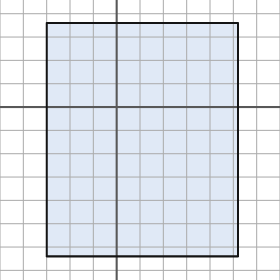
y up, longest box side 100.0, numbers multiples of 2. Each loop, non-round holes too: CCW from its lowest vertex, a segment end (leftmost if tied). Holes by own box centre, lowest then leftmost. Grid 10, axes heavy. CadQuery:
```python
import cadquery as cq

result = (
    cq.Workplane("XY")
    .moveTo(-30.0, -64.0)
    .lineTo(52.0, -64.0)
    .lineTo(52.0, 36.0)
    .lineTo(-30.0, 36.0)
    .close()
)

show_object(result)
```